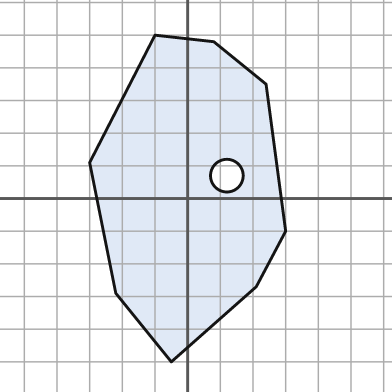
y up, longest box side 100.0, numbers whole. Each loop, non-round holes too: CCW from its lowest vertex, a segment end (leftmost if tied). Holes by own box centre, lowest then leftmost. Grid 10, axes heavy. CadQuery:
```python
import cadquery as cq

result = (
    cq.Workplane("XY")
    .moveTo(-5.0, -50.0)
    .lineTo(21.0, -27.0)
    .lineTo(30.0, -10.0)
    .lineTo(24.0, 35.0)
    .lineTo(8.0, 48.0)
    .lineTo(-10.0, 50.0)
    .lineTo(-30.0, 11.0)
    .lineTo(-22.0, -29.0)
    .close()
    .moveTo(12.0, 7.0)
    .circle(5.0)
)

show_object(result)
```